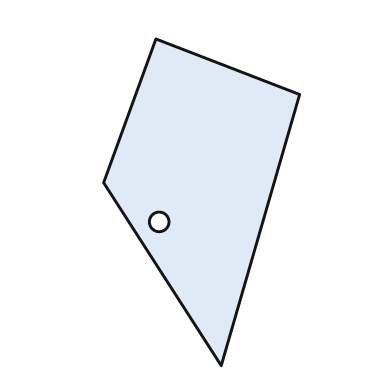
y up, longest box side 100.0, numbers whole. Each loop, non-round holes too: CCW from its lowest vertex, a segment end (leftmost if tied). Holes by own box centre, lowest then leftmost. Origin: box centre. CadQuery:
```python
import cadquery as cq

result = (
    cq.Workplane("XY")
    .moveTo(6.0, -50.0)
    .lineTo(30.0, 33.0)
    .lineTo(-14.0, 50.0)
    .lineTo(-30.0, 6.0)
    .close()
    .moveTo(-13.0, -6.0)
    .circle(3.0)
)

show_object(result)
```